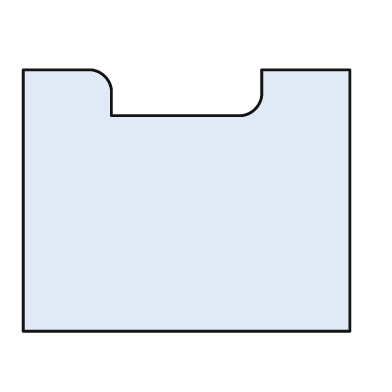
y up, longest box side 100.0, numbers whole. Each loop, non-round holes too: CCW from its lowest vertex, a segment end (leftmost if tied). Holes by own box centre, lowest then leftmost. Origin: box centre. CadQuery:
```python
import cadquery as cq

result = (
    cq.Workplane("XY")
    .moveTo(-50.0, -40.0)
    .lineTo(50.0, -40.0)
    .lineTo(50.0, 40.0)
    .lineTo(23.0, 40.0)
    .lineTo(23.0, 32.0)
    .threePointArc((21.0, 28.0), (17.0, 26.0))
    .lineTo(-23.0, 26.0)
    .lineTo(-23.0, 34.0)
    .threePointArc((-25.0, 38.0), (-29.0, 40.0))
    .lineTo(-50.0, 40.0)
    .close()
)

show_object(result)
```